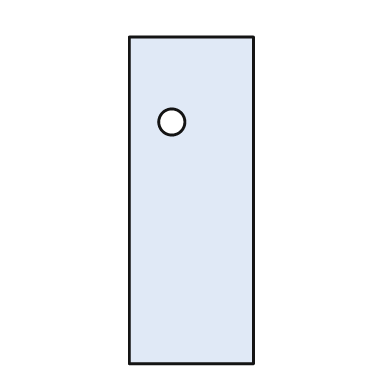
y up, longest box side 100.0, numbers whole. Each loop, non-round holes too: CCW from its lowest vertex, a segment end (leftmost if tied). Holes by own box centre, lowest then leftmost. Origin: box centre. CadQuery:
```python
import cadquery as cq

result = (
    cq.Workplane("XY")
    .moveTo(-19.0, -50.0)
    .lineTo(19.0, -50.0)
    .lineTo(19.0, 50.0)
    .lineTo(-19.0, 50.0)
    .close()
    .moveTo(-6.0, 24.0)
    .circle(4.0)
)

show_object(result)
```